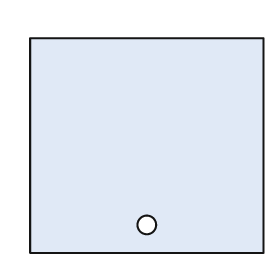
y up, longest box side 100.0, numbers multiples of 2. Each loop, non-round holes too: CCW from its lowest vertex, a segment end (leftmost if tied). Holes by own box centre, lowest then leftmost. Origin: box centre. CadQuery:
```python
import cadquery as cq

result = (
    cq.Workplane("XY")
    .moveTo(-50.0, -46.0)
    .lineTo(50.0, -46.0)
    .lineTo(50.0, 46.0)
    .lineTo(-50.0, 46.0)
    .close()
    .moveTo(0.0, -34.0)
    .circle(4.0)
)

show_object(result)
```